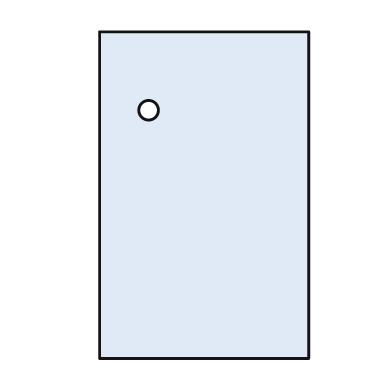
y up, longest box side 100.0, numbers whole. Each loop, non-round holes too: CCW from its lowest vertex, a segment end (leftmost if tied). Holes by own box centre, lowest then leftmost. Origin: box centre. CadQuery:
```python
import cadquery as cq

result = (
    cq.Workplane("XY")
    .moveTo(-32.0, -50.0)
    .lineTo(32.0, -50.0)
    .lineTo(32.0, 50.0)
    .lineTo(-32.0, 50.0)
    .close()
    .moveTo(-17.0, 26.0)
    .circle(3.0)
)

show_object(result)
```